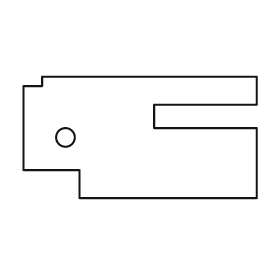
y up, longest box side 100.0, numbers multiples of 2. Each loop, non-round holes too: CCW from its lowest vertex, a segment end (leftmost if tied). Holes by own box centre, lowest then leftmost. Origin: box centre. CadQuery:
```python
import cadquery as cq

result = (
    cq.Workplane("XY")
    .moveTo(-26.0, -26.0)
    .lineTo(50.0, -26.0)
    .lineTo(50.0, 4.0)
    .lineTo(6.0, 4.0)
    .lineTo(6.0, 14.0)
    .lineTo(50.0, 14.0)
    .lineTo(50.0, 26.0)
    .lineTo(-42.0, 26.0)
    .lineTo(-42.0, 22.0)
    .lineTo(-50.0, 22.0)
    .lineTo(-50.0, -14.0)
    .lineTo(-26.0, -14.0)
    .close()
    .moveTo(-32.0, 0.0)
    .circle(4.0)
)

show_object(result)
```